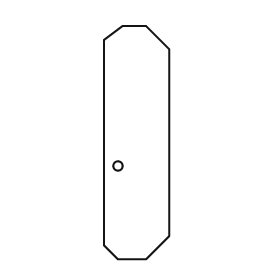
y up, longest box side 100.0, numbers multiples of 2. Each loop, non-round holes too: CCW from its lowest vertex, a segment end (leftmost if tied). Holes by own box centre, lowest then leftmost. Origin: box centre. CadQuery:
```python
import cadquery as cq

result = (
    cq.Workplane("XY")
    .moveTo(-8.0, -50.0)
    .lineTo(4.0, -50.0)
    .lineTo(14.0, -40.0)
    .lineTo(14.0, 40.0)
    .lineTo(4.0, 50.0)
    .lineTo(-6.0, 50.0)
    .lineTo(-14.0, 44.0)
    .lineTo(-14.0, -44.0)
    .close()
    .moveTo(-8.0, -10.0)
    .circle(2.0)
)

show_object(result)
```